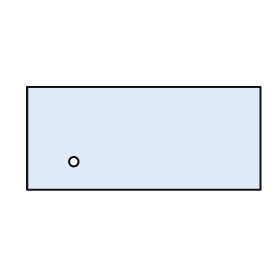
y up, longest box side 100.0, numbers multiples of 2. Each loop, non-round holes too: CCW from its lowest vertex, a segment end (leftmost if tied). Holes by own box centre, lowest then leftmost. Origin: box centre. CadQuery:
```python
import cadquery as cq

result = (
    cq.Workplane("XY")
    .moveTo(-50.0, -22.0)
    .lineTo(50.0, -22.0)
    .lineTo(50.0, 22.0)
    .lineTo(-50.0, 22.0)
    .close()
    .moveTo(-30.0, -10.0)
    .circle(2.0)
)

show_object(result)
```